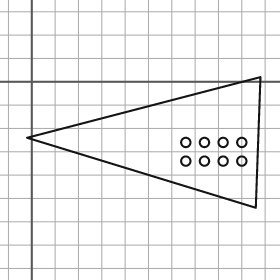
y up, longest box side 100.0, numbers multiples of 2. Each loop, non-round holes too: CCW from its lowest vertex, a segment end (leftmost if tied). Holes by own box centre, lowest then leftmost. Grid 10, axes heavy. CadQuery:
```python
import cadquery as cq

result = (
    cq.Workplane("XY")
    .moveTo(96.0, -54.0)
    .lineTo(98.0, 2.0)
    .lineTo(-2.0, -24.0)
    .close()
    .moveTo(66.0, -34.0)
    .circle(2.0)
    .moveTo(74.0, -34.0)
    .circle(2.0)
    .moveTo(82.0, -34.0)
    .circle(2.0)
    .moveTo(90.0, -34.0)
    .circle(2.0)
    .moveTo(66.0, -26.0)
    .circle(2.0)
    .moveTo(74.0, -26.0)
    .circle(2.0)
    .moveTo(82.0, -26.0)
    .circle(2.0)
    .moveTo(90.0, -26.0)
    .circle(2.0)
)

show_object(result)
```